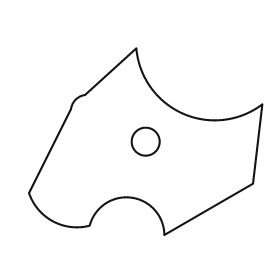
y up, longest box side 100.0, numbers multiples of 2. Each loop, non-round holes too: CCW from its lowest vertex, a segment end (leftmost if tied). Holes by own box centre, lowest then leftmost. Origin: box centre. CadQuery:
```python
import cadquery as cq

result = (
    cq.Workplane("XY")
    .moveTo(8.0, -40.0)
    .lineTo(46.0, -18.0)
    .lineTo(50.0, 16.0)
    .threePointArc((16.0, 12.0), (-4.0, 40.0))
    .lineTo(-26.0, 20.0)
    .threePointArc((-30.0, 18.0), (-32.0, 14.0))
    .lineTo(-50.0, -22.0)
    .threePointArc((-40.0, -34.0), (-24.0, -36.0))
    .threePointArc((-6.0, -24.0), (8.0, -40.0))
    .close()
    .moveTo(0.0, 0.0)
    .circle(6.0)
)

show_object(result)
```